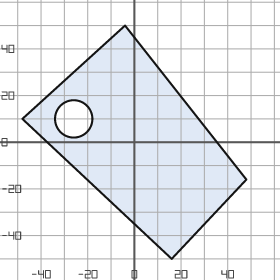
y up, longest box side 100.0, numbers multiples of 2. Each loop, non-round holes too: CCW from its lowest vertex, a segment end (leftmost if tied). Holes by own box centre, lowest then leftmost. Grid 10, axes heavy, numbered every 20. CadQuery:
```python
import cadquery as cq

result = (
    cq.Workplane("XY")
    .moveTo(16.0, -50.0)
    .lineTo(48.0, -16.0)
    .lineTo(-4.0, 50.0)
    .lineTo(-48.0, 10.0)
    .close()
    .moveTo(-26.0, 10.0)
    .circle(8.0)
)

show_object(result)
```